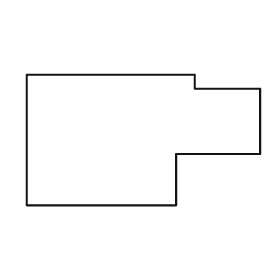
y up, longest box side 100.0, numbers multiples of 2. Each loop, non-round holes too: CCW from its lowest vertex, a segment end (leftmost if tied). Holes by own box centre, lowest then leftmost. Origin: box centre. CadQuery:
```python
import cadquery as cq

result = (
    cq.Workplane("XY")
    .moveTo(-50.0, -28.0)
    .lineTo(14.0, -28.0)
    .lineTo(14.0, -6.0)
    .lineTo(50.0, -6.0)
    .lineTo(50.0, 22.0)
    .lineTo(22.0, 22.0)
    .lineTo(22.0, 28.0)
    .lineTo(-50.0, 28.0)
    .close()
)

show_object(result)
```